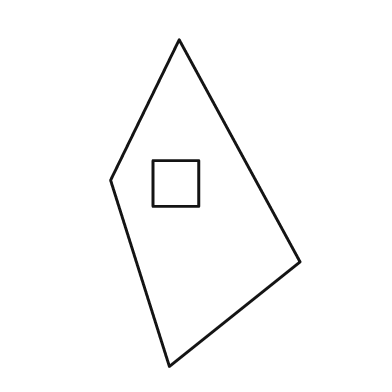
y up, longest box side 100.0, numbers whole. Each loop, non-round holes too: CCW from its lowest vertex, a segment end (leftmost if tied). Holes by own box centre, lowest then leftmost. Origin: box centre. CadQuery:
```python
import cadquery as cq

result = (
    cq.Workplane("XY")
    .moveTo(-11.0, -50.0)
    .lineTo(29.0, -18.0)
    .lineTo(-8.0, 50.0)
    .lineTo(-29.0, 7.0)
    .close()
    .moveTo(-16.0, -1.0)
    .lineTo(-2.0, -1.0)
    .lineTo(-2.0, 13.0)
    .lineTo(-16.0, 13.0)
    .close()
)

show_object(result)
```